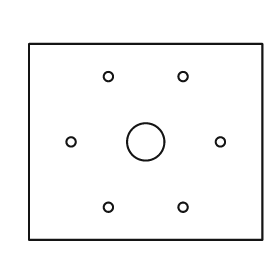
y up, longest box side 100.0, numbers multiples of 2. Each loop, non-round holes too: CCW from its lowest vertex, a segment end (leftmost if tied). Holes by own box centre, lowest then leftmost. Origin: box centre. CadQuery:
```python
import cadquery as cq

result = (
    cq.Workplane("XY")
    .moveTo(-50.0, -42.0)
    .lineTo(50.0, -42.0)
    .lineTo(50.0, 42.0)
    .lineTo(-50.0, 42.0)
    .close()
    .moveTo(-16.0, -28.0)
    .circle(2.0)
    .moveTo(16.0, -28.0)
    .circle(2.0)
    .moveTo(-32.0, 0.0)
    .circle(2.0)
    .moveTo(0.0, 0.0)
    .circle(8.0)
    .moveTo(32.0, 0.0)
    .circle(2.0)
    .moveTo(-16.0, 28.0)
    .circle(2.0)
    .moveTo(16.0, 28.0)
    .circle(2.0)
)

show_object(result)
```